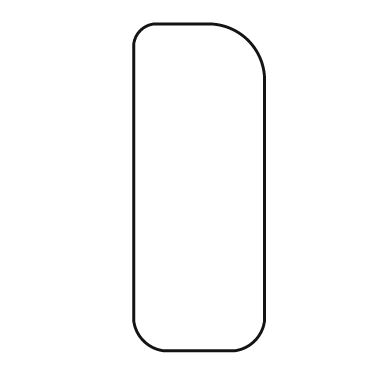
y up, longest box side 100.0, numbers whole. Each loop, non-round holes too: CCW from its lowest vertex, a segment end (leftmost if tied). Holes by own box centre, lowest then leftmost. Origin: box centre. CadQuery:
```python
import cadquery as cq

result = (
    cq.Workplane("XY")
    .moveTo(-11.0, -50.0)
    .lineTo(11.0, -50.0)
    .threePointArc((17.0, -47.0), (20.0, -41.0))
    .lineTo(20.0, 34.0)
    .threePointArc((15.0, 45.0), (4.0, 50.0))
    .lineTo(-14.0, 50.0)
    .threePointArc((-18.0, 48.0), (-20.0, 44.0))
    .lineTo(-20.0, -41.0)
    .threePointArc((-17.0, -47.0), (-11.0, -50.0))
    .close()
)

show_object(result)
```